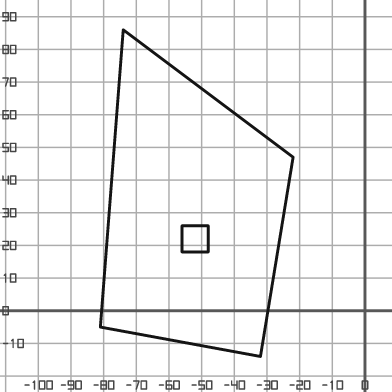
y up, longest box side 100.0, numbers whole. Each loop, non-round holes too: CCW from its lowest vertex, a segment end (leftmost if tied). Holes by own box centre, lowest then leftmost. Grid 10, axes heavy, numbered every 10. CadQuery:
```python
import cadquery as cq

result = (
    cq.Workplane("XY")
    .moveTo(-32.0, -14.0)
    .lineTo(-22.0, 47.0)
    .lineTo(-74.0, 86.0)
    .lineTo(-81.0, -5.0)
    .close()
    .moveTo(-56.0, 18.0)
    .lineTo(-48.0, 18.0)
    .lineTo(-48.0, 26.0)
    .lineTo(-56.0, 26.0)
    .close()
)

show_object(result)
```